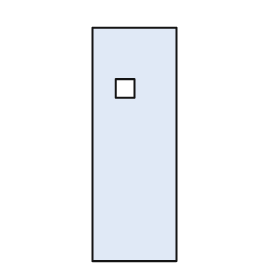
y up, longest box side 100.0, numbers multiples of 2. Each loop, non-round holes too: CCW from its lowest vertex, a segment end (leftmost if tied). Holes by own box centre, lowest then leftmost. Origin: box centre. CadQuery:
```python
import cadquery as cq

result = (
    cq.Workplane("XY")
    .moveTo(-18.0, -50.0)
    .lineTo(18.0, -50.0)
    .lineTo(18.0, 50.0)
    .lineTo(-18.0, 50.0)
    .close()
    .moveTo(-8.0, 20.0)
    .lineTo(0.0, 20.0)
    .lineTo(0.0, 28.0)
    .lineTo(-8.0, 28.0)
    .close()
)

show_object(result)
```